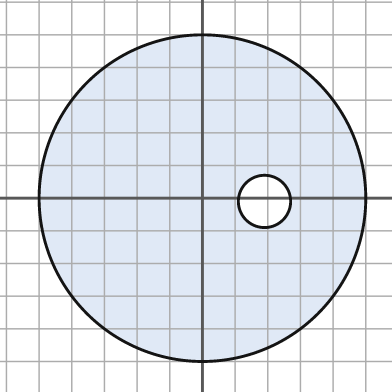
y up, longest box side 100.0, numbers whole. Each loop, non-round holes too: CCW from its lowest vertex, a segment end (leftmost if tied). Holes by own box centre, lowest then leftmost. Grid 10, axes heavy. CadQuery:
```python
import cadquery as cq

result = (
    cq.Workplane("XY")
    .moveTo(0.0, 0.0)
    .circle(50.0)
    .moveTo(19.0, -1.0)
    .circle(8.0)
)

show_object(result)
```